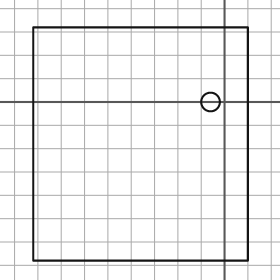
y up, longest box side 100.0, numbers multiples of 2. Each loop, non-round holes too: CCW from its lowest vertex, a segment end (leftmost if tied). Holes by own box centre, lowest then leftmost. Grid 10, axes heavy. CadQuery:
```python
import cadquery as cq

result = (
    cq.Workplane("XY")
    .moveTo(-82.0, -68.0)
    .lineTo(10.0, -68.0)
    .lineTo(10.0, 32.0)
    .lineTo(-82.0, 32.0)
    .close()
    .moveTo(-6.0, 0.0)
    .circle(4.0)
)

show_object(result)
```